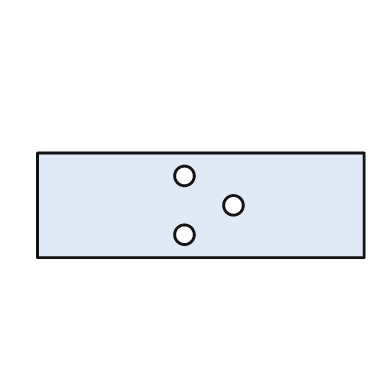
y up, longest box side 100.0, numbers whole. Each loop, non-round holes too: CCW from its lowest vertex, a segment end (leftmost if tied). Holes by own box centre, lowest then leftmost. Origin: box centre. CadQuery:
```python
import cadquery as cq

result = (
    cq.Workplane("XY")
    .moveTo(-50.0, -16.0)
    .lineTo(50.0, -16.0)
    .lineTo(50.0, 16.0)
    .lineTo(-50.0, 16.0)
    .close()
    .moveTo(-5.0, -9.0)
    .circle(3.0)
    .moveTo(10.0, 0.0)
    .circle(3.0)
    .moveTo(-5.0, 9.0)
    .circle(3.0)
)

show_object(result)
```